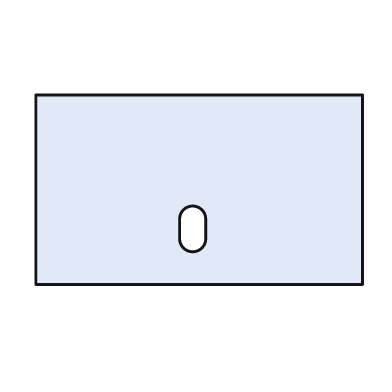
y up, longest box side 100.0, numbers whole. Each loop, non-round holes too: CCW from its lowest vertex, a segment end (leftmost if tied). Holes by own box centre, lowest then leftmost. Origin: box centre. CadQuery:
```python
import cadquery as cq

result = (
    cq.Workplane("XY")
    .moveTo(-50.0, -29.0)
    .lineTo(50.0, -29.0)
    .lineTo(50.0, 29.0)
    .lineTo(-50.0, 29.0)
    .close()
    .moveTo(-6.0, -15.0)
    .threePointArc((-2.0, -19.0), (2.0, -15.0))
    .lineTo(2.0, -9.0)
    .threePointArc((-2.0, -5.0), (-6.0, -9.0))
    .close()
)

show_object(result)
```